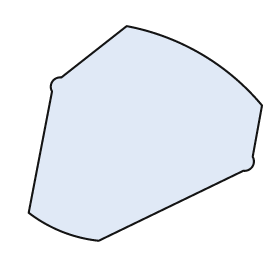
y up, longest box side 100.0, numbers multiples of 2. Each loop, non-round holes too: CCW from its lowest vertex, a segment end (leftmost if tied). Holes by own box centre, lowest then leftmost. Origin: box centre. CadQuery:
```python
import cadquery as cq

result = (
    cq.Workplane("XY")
    .moveTo(-20.0, -46.0)
    .lineTo(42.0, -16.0)
    .threePointArc((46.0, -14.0), (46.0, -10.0))
    .lineTo(50.0, 12.0)
    .threePointArc((24.0, 34.0), (-8.0, 46.0))
    .lineTo(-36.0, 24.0)
    .threePointArc((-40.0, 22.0), (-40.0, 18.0))
    .lineTo(-50.0, -34.0)
    .threePointArc((-36.0, -42.0), (-20.0, -46.0))
    .close()
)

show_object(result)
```